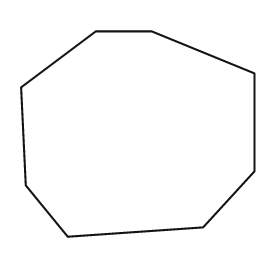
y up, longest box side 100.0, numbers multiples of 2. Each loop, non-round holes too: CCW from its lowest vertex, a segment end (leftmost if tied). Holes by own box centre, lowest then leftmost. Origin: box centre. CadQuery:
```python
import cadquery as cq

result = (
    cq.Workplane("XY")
    .moveTo(-30.0, -44.0)
    .lineTo(28.0, -40.0)
    .lineTo(50.0, -16.0)
    .lineTo(50.0, 26.0)
    .lineTo(6.0, 44.0)
    .lineTo(-18.0, 44.0)
    .lineTo(-50.0, 20.0)
    .lineTo(-48.0, -22.0)
    .close()
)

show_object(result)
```